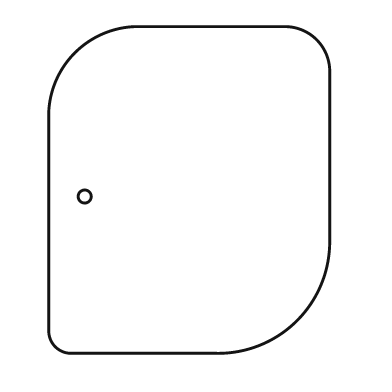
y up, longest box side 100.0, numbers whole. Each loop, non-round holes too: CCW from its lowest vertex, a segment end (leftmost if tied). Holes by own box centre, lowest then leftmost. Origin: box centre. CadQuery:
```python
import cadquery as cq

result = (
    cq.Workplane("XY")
    .moveTo(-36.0, -50.0)
    .lineTo(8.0, -50.0)
    .threePointArc((33.0, -40.0), (43.0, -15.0))
    .lineTo(43.0, 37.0)
    .threePointArc((39.0, 46.0), (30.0, 50.0))
    .lineTo(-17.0, 50.0)
    .threePointArc((-35.0, 42.0), (-43.0, 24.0))
    .lineTo(-43.0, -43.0)
    .threePointArc((-41.0, -48.0), (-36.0, -50.0))
    .close()
    .moveTo(-32.0, -2.0)
    .circle(2.0)
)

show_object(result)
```